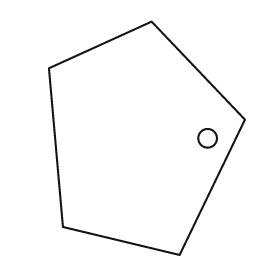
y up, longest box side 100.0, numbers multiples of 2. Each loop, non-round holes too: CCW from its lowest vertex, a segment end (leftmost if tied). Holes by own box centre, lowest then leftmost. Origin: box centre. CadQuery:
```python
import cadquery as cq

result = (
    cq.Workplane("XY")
    .moveTo(14.0, -50.0)
    .lineTo(42.0, 8.0)
    .lineTo(2.0, 50.0)
    .lineTo(-42.0, 30.0)
    .lineTo(-36.0, -38.0)
    .close()
    .moveTo(26.0, 0.0)
    .circle(4.0)
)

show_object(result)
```